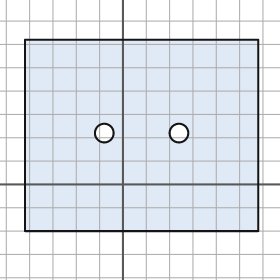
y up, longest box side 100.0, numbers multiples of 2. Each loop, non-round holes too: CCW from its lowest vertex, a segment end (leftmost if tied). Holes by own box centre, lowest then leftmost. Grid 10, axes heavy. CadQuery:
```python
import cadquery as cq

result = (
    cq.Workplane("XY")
    .moveTo(-42.0, -20.0)
    .lineTo(58.0, -20.0)
    .lineTo(58.0, 62.0)
    .lineTo(-42.0, 62.0)
    .close()
    .moveTo(-8.0, 22.0)
    .circle(4.0)
    .moveTo(24.0, 22.0)
    .circle(4.0)
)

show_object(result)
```